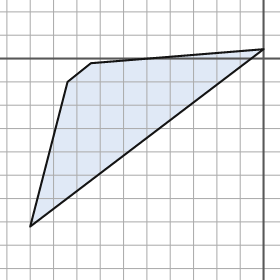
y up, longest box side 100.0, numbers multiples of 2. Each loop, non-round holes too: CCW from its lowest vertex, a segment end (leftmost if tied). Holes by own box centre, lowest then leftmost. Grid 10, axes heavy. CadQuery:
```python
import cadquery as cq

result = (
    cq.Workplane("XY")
    .moveTo(-100.0, -72.0)
    .lineTo(0.0, 4.0)
    .lineTo(-74.0, -2.0)
    .lineTo(-84.0, -10.0)
    .close()
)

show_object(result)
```